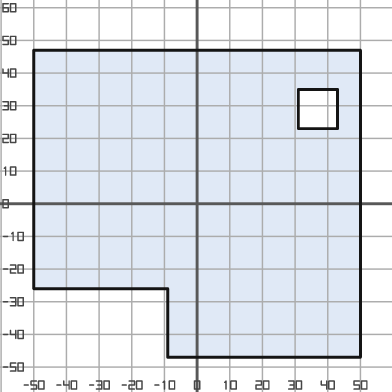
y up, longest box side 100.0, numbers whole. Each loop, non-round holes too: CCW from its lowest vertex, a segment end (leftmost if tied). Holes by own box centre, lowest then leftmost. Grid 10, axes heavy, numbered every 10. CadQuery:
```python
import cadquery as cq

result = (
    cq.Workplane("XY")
    .moveTo(-9.0, -47.0)
    .lineTo(50.0, -47.0)
    .lineTo(50.0, 47.0)
    .lineTo(-50.0, 47.0)
    .lineTo(-50.0, -26.0)
    .lineTo(-9.0, -26.0)
    .close()
    .moveTo(31.0, 23.0)
    .lineTo(43.0, 23.0)
    .lineTo(43.0, 35.0)
    .lineTo(31.0, 35.0)
    .close()
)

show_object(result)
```